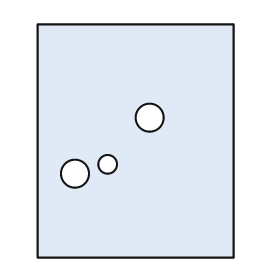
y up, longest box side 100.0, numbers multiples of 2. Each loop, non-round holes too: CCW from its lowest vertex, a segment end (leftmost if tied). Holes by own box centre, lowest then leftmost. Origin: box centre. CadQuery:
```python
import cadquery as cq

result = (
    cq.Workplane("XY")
    .moveTo(-42.0, -50.0)
    .lineTo(42.0, -50.0)
    .lineTo(42.0, 50.0)
    .lineTo(-42.0, 50.0)
    .close()
    .moveTo(-26.0, -14.0)
    .circle(6.0)
    .moveTo(-12.0, -10.0)
    .circle(4.0)
    .moveTo(6.0, 10.0)
    .circle(6.0)
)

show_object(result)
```